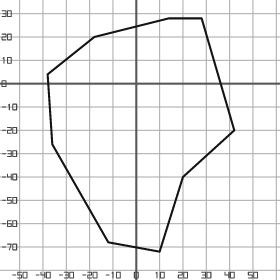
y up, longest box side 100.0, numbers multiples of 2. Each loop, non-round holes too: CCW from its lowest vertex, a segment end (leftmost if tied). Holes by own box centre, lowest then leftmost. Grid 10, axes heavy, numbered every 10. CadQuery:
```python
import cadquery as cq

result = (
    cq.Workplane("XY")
    .moveTo(10.0, -72.0)
    .lineTo(20.0, -40.0)
    .lineTo(42.0, -20.0)
    .lineTo(28.0, 28.0)
    .lineTo(14.0, 28.0)
    .lineTo(-18.0, 20.0)
    .lineTo(-38.0, 4.0)
    .lineTo(-36.0, -26.0)
    .lineTo(-12.0, -68.0)
    .close()
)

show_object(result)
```